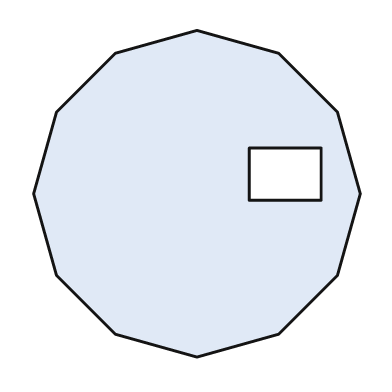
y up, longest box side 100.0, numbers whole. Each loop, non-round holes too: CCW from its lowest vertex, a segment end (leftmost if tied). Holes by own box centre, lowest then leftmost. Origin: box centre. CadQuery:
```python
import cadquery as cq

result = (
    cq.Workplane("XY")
    .moveTo(0.0, -50.0)
    .lineTo(25.0, -43.0)
    .lineTo(43.0, -25.0)
    .lineTo(50.0, 0.0)
    .lineTo(43.0, 25.0)
    .lineTo(25.0, 43.0)
    .lineTo(0.0, 50.0)
    .lineTo(-25.0, 43.0)
    .lineTo(-43.0, 25.0)
    .lineTo(-50.0, 0.0)
    .lineTo(-43.0, -25.0)
    .lineTo(-25.0, -43.0)
    .close()
    .moveTo(16.0, -2.0)
    .lineTo(38.0, -2.0)
    .lineTo(38.0, 14.0)
    .lineTo(16.0, 14.0)
    .close()
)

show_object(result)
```